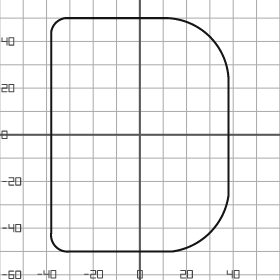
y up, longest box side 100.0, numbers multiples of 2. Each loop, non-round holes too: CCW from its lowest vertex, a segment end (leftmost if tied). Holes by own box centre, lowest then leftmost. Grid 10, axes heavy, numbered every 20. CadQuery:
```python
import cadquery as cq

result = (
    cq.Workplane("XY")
    .moveTo(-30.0, -50.0)
    .lineTo(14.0, -50.0)
    .threePointArc((30.0, -42.0), (38.0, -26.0))
    .lineTo(38.0, 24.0)
    .threePointArc((30.0, 42.0), (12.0, 50.0))
    .lineTo(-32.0, 50.0)
    .threePointArc((-36.0, 48.0), (-38.0, 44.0))
    .lineTo(-38.0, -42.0)
    .threePointArc((-36.0, -48.0), (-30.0, -50.0))
    .close()
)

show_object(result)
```